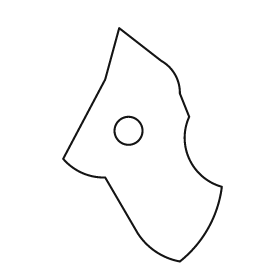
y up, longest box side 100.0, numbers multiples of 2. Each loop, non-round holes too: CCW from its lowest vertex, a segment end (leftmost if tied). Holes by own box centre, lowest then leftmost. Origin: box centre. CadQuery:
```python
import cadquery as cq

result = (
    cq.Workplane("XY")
    .moveTo(16.0, -50.0)
    .threePointArc((28.0, -36.0), (34.0, -18.0))
    .threePointArc((20.0, -6.0), (20.0, 12.0))
    .lineTo(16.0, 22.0)
    .threePointArc((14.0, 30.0), (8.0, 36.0))
    .lineTo(-10.0, 50.0)
    .lineTo(-16.0, 28.0)
    .lineTo(-34.0, -6.0)
    .threePointArc((-26.0, -12.0), (-16.0, -14.0))
    .lineTo(-2.0, -38.0)
    .threePointArc((6.0, -46.0), (16.0, -50.0))
    .close()
    .moveTo(-6.0, 6.0)
    .circle(6.0)
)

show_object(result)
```